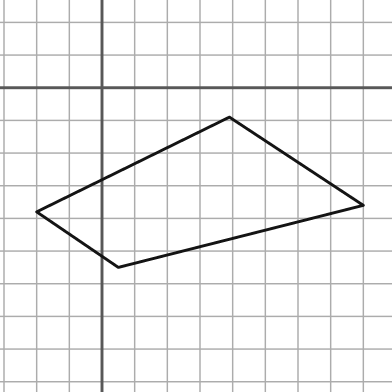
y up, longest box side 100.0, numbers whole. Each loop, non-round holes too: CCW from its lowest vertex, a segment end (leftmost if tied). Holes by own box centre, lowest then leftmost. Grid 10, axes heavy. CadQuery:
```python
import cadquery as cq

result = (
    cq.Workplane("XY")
    .moveTo(5.0, -55.0)
    .lineTo(80.0, -36.0)
    .lineTo(39.0, -9.0)
    .lineTo(-20.0, -38.0)
    .close()
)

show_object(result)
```